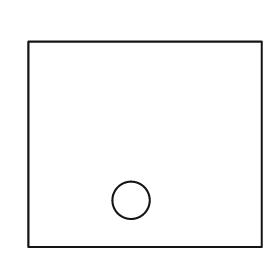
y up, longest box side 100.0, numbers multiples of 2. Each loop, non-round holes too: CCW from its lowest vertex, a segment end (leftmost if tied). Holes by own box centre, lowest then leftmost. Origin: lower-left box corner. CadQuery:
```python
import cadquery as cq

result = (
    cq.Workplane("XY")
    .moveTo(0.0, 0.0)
    .lineTo(100.0, 0.0)
    .lineTo(100.0, 88.0)
    .lineTo(0.0, 88.0)
    .close()
    .moveTo(44.0, 20.0)
    .circle(8.0)
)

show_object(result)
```